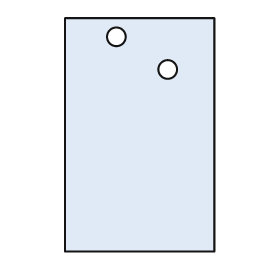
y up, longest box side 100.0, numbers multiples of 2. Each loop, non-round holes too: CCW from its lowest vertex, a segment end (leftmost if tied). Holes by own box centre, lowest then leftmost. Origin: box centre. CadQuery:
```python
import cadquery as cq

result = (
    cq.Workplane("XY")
    .moveTo(-32.0, -50.0)
    .lineTo(32.0, -50.0)
    .lineTo(32.0, 50.0)
    .lineTo(-32.0, 50.0)
    .close()
    .moveTo(12.0, 28.0)
    .circle(4.0)
    .moveTo(-10.0, 42.0)
    .circle(4.0)
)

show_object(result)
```